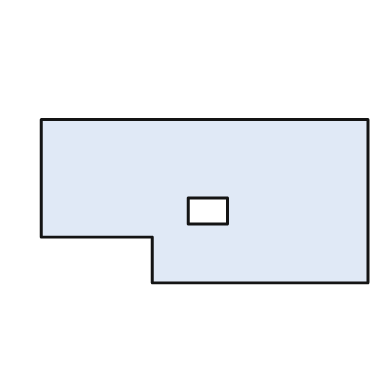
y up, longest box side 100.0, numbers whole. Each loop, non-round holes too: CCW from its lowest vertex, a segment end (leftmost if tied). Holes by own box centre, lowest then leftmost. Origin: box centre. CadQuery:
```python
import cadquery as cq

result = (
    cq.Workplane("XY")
    .moveTo(-16.0, -25.0)
    .lineTo(50.0, -25.0)
    .lineTo(50.0, 25.0)
    .lineTo(-50.0, 25.0)
    .lineTo(-50.0, -11.0)
    .lineTo(-16.0, -11.0)
    .close()
    .moveTo(-5.0, -7.0)
    .lineTo(7.0, -7.0)
    .lineTo(7.0, 1.0)
    .lineTo(-5.0, 1.0)
    .close()
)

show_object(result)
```